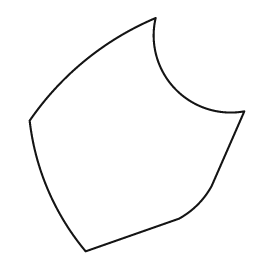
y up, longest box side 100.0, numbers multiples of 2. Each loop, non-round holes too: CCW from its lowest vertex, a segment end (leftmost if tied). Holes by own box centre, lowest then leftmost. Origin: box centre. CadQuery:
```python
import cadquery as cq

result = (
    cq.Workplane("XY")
    .moveTo(-22.0, -50.0)
    .lineTo(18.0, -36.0)
    .threePointArc((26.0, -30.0), (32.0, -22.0))
    .lineTo(46.0, 10.0)
    .threePointArc((16.0, 20.0), (8.0, 50.0))
    .threePointArc((-22.0, 32.0), (-46.0, 6.0))
    .threePointArc((-38.0, -24.0), (-22.0, -50.0))
    .close()
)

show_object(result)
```